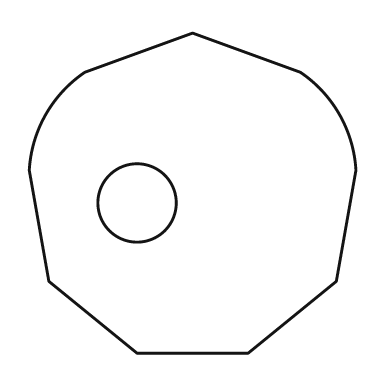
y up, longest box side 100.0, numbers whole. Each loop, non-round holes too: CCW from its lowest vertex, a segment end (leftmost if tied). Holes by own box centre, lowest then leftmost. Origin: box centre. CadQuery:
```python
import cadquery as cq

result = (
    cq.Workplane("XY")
    .moveTo(-17.0, -49.0)
    .lineTo(17.0, -49.0)
    .lineTo(44.0, -27.0)
    .lineTo(50.0, 7.0)
    .threePointArc((45.0, 24.0), (33.0, 37.0))
    .lineTo(0.0, 49.0)
    .lineTo(-33.0, 37.0)
    .threePointArc((-45.0, 24.0), (-50.0, 7.0))
    .lineTo(-44.0, -27.0)
    .close()
    .moveTo(-17.0, -3.0)
    .circle(12.0)
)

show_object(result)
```